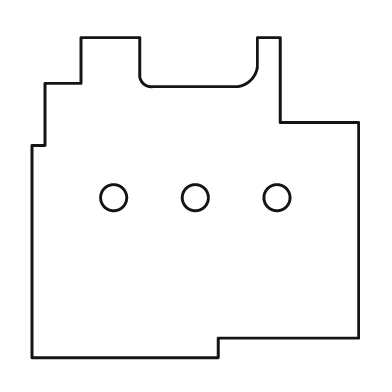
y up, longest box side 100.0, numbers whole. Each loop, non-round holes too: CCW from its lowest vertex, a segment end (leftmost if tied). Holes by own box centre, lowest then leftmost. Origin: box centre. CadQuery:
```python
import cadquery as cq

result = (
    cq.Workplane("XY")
    .moveTo(-50.0, -49.0)
    .lineTo(7.0, -49.0)
    .lineTo(7.0, -43.0)
    .lineTo(50.0, -43.0)
    .lineTo(50.0, 23.0)
    .lineTo(26.0, 23.0)
    .lineTo(26.0, 49.0)
    .lineTo(19.0, 49.0)
    .lineTo(19.0, 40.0)
    .threePointArc((17.0, 36.0), (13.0, 34.0))
    .lineTo(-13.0, 34.0)
    .threePointArc((-16.0, 35.0), (-17.0, 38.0))
    .lineTo(-17.0, 49.0)
    .lineTo(-35.0, 49.0)
    .lineTo(-35.0, 35.0)
    .lineTo(-46.0, 35.0)
    .lineTo(-46.0, 16.0)
    .lineTo(-50.0, 16.0)
    .close()
    .moveTo(-25.0, 0.0)
    .circle(4.0)
    .moveTo(0.0, 0.0)
    .circle(4.0)
    .moveTo(25.0, 0.0)
    .circle(4.0)
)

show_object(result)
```